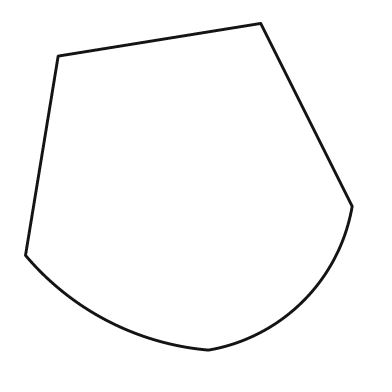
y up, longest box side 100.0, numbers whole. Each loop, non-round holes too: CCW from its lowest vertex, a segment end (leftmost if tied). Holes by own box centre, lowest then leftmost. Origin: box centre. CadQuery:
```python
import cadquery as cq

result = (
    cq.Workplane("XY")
    .moveTo(6.0, -50.0)
    .threePointArc((35.0, -35.0), (50.0, -6.0))
    .lineTo(22.0, 50.0)
    .lineTo(-40.0, 40.0)
    .lineTo(-50.0, -21.0)
    .threePointArc((-25.0, -41.0), (6.0, -50.0))
    .close()
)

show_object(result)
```